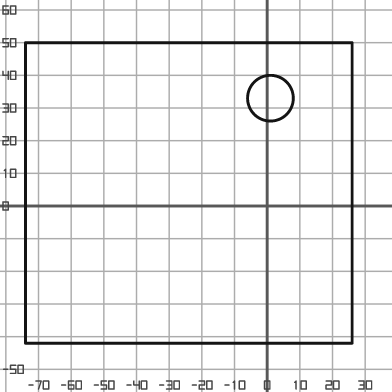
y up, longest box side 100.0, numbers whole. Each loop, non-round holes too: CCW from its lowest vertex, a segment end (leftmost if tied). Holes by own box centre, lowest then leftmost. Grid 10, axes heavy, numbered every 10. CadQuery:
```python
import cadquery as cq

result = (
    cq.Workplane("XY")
    .moveTo(-74.0, -42.0)
    .lineTo(26.0, -42.0)
    .lineTo(26.0, 50.0)
    .lineTo(-74.0, 50.0)
    .close()
    .moveTo(1.0, 33.0)
    .circle(7.0)
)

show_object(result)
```